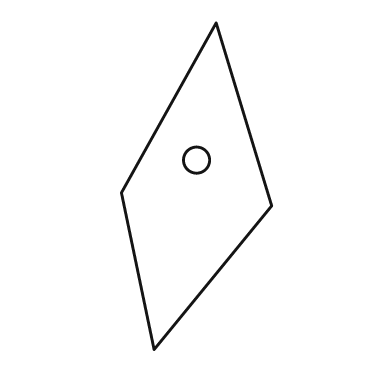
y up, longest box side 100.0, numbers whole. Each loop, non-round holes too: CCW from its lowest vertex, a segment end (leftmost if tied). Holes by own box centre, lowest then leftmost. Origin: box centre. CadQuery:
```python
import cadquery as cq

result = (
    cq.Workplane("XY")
    .moveTo(-13.0, -50.0)
    .lineTo(23.0, -6.0)
    .lineTo(6.0, 50.0)
    .lineTo(-23.0, -2.0)
    .close()
    .moveTo(0.0, 8.0)
    .circle(4.0)
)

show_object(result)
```